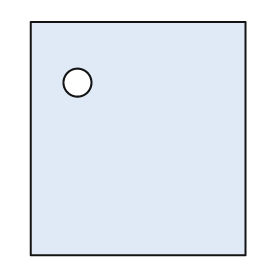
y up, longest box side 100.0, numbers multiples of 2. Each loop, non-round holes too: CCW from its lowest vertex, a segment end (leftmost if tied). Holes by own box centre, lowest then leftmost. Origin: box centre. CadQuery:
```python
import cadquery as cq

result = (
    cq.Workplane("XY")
    .moveTo(-46.0, -50.0)
    .lineTo(46.0, -50.0)
    .lineTo(46.0, 50.0)
    .lineTo(-46.0, 50.0)
    .close()
    .moveTo(-26.0, 24.0)
    .circle(6.0)
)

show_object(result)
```